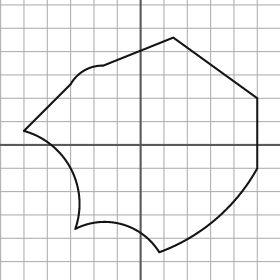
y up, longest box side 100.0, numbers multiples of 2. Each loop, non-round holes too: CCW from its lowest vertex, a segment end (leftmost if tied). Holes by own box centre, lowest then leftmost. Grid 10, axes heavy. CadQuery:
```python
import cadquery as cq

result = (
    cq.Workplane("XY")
    .moveTo(8.0, -46.0)
    .threePointArc((32.0, -32.0), (50.0, -10.0))
    .lineTo(50.0, 20.0)
    .lineTo(14.0, 46.0)
    .lineTo(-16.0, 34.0)
    .threePointArc((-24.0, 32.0), (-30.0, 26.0))
    .lineTo(-50.0, 6.0)
    .threePointArc((-30.0, -10.0), (-28.0, -36.0))
    .threePointArc((-8.0, -34.0), (8.0, -46.0))
    .close()
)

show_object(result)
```